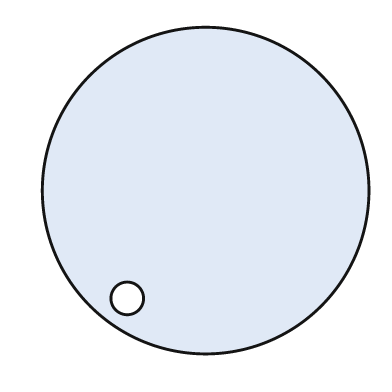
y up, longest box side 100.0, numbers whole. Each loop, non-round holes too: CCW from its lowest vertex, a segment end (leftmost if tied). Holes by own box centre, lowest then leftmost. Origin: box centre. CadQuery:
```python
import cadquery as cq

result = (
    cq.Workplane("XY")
    .moveTo(0.0, 0.0)
    .circle(50.0)
    .moveTo(-24.0, -33.0)
    .circle(5.0)
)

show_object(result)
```